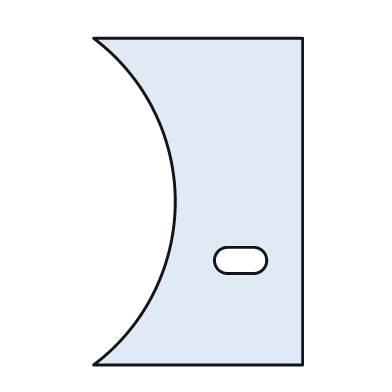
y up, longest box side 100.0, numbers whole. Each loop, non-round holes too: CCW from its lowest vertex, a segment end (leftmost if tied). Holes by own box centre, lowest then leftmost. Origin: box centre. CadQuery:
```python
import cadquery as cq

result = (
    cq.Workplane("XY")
    .moveTo(-32.0, -50.0)
    .lineTo(32.0, -50.0)
    .lineTo(32.0, 50.0)
    .lineTo(-32.0, 50.0)
    .threePointArc((-7.0, 0.0), (-32.0, -50.0))
    .close()
    .moveTo(9.0, -22.0)
    .lineTo(17.0, -22.0)
    .threePointArc((21.0, -18.0), (17.0, -14.0))
    .lineTo(9.0, -14.0)
    .threePointArc((5.0, -18.0), (9.0, -22.0))
    .close()
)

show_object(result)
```